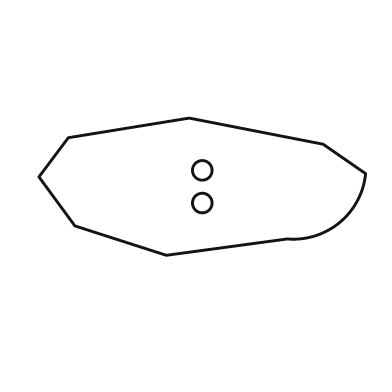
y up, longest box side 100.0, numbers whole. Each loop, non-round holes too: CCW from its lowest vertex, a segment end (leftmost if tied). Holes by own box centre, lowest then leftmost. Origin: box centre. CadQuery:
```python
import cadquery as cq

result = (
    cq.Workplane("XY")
    .moveTo(-11.0, -21.0)
    .lineTo(26.0, -16.0)
    .threePointArc((42.0, -11.0), (50.0, 4.0))
    .lineTo(37.0, 13.0)
    .lineTo(-4.0, 21.0)
    .lineTo(-41.0, 15.0)
    .lineTo(-50.0, 3.0)
    .lineTo(-39.0, -12.0)
    .close()
    .moveTo(0.0, -5.0)
    .circle(3.0)
    .moveTo(0.0, 5.0)
    .circle(3.0)
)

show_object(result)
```